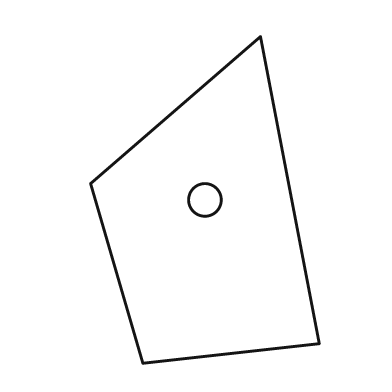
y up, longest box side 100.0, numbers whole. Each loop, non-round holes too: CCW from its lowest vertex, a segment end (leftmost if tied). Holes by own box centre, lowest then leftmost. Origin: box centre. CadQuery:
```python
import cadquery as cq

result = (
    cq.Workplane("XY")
    .moveTo(-19.0, -50.0)
    .lineTo(35.0, -44.0)
    .lineTo(17.0, 50.0)
    .lineTo(-35.0, 5.0)
    .close()
    .moveTo(0.0, 0.0)
    .circle(5.0)
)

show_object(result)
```